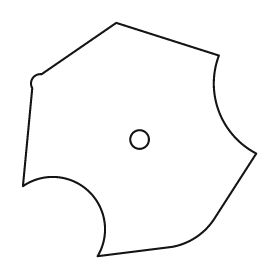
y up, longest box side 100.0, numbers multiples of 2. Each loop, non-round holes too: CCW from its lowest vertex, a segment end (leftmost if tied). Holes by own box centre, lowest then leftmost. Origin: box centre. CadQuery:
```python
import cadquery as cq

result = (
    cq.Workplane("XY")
    .moveTo(-18.0, -50.0)
    .lineTo(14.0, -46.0)
    .threePointArc((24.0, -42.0), (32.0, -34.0))
    .lineTo(50.0, -6.0)
    .threePointArc((34.0, 12.0), (34.0, 36.0))
    .lineTo(-10.0, 50.0)
    .lineTo(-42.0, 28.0)
    .threePointArc((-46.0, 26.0), (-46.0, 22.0))
    .lineTo(-50.0, -20.0)
    .threePointArc((-22.0, -22.0), (-18.0, -50.0))
    .close()
    .moveTo(0.0, 0.0)
    .circle(4.0)
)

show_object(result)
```